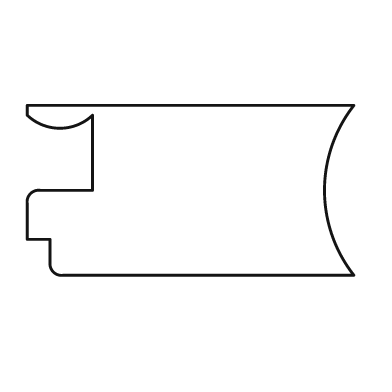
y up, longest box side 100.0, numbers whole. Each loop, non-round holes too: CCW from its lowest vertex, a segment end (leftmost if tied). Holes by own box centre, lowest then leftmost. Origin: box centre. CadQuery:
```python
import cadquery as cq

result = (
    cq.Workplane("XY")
    .moveTo(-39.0, -26.0)
    .lineTo(50.0, -26.0)
    .threePointArc((41.0, 0.0), (50.0, 26.0))
    .lineTo(-50.0, 26.0)
    .lineTo(-50.0, 23.0)
    .threePointArc((-40.0, 19.0), (-30.0, 23.0))
    .lineTo(-30.0, 0.0)
    .lineTo(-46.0, 0.0)
    .threePointArc((-49.0, -1.0), (-50.0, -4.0))
    .lineTo(-50.0, -15.0)
    .lineTo(-43.0, -15.0)
    .lineTo(-43.0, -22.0)
    .threePointArc((-42.0, -25.0), (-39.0, -26.0))
    .close()
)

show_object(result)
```